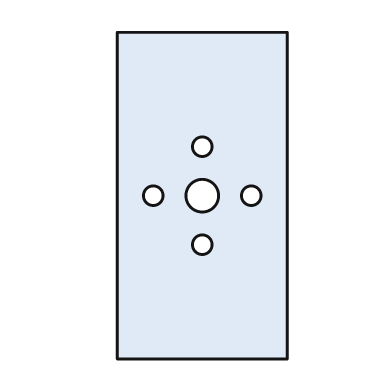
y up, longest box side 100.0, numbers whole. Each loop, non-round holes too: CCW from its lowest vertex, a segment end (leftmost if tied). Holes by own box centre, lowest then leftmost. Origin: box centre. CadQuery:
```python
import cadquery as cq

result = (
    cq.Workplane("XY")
    .moveTo(-26.0, -50.0)
    .lineTo(26.0, -50.0)
    .lineTo(26.0, 50.0)
    .lineTo(-26.0, 50.0)
    .close()
    .moveTo(0.0, -15.0)
    .circle(3.0)
    .moveTo(-15.0, 0.0)
    .circle(3.0)
    .moveTo(0.0, 0.0)
    .circle(5.0)
    .moveTo(15.0, 0.0)
    .circle(3.0)
    .moveTo(0.0, 15.0)
    .circle(3.0)
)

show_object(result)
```